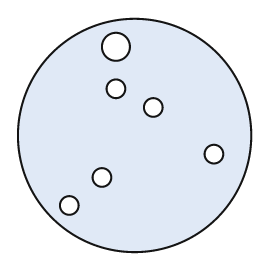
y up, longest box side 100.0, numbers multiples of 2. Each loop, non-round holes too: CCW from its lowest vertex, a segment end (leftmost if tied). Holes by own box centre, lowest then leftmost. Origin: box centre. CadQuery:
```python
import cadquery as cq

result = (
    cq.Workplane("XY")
    .moveTo(0.0, 0.0)
    .circle(50.0)
    .moveTo(-28.0, -30.0)
    .circle(4.0)
    .moveTo(-14.0, -18.0)
    .circle(4.0)
    .moveTo(34.0, -8.0)
    .circle(4.0)
    .moveTo(8.0, 12.0)
    .circle(4.0)
    .moveTo(-8.0, 20.0)
    .circle(4.0)
    .moveTo(-8.0, 38.0)
    .circle(6.0)
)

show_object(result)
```